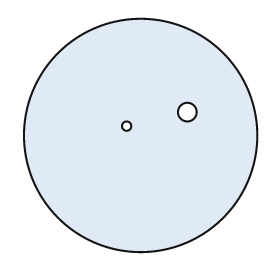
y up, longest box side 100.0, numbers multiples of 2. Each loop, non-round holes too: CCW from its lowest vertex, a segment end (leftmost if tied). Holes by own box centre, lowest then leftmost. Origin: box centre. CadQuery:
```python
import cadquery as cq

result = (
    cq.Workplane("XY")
    .moveTo(0.0, 0.0)
    .circle(50.0)
    .moveTo(-6.0, 4.0)
    .circle(2.0)
    .moveTo(20.0, 10.0)
    .circle(4.0)
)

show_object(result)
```